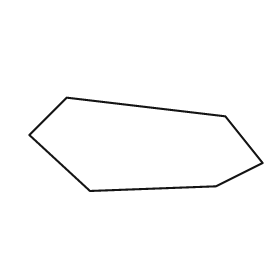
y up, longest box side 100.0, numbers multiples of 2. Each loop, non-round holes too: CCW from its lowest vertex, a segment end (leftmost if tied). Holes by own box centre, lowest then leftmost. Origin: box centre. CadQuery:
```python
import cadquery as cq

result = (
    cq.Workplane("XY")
    .moveTo(-24.0, -20.0)
    .lineTo(30.0, -18.0)
    .lineTo(50.0, -8.0)
    .lineTo(34.0, 12.0)
    .lineTo(-34.0, 20.0)
    .lineTo(-50.0, 4.0)
    .close()
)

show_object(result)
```